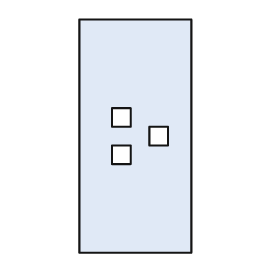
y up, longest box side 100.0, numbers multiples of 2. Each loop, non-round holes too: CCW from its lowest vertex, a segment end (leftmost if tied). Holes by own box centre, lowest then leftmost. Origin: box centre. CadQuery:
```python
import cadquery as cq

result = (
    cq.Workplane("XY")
    .moveTo(-24.0, -50.0)
    .lineTo(24.0, -50.0)
    .lineTo(24.0, 50.0)
    .lineTo(-24.0, 50.0)
    .close()
    .moveTo(-10.0, -12.0)
    .lineTo(-2.0, -12.0)
    .lineTo(-2.0, -4.0)
    .lineTo(-10.0, -4.0)
    .close()
    .moveTo(6.0, -4.0)
    .lineTo(14.0, -4.0)
    .lineTo(14.0, 4.0)
    .lineTo(6.0, 4.0)
    .close()
    .moveTo(-10.0, 4.0)
    .lineTo(-2.0, 4.0)
    .lineTo(-2.0, 12.0)
    .lineTo(-10.0, 12.0)
    .close()
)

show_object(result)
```